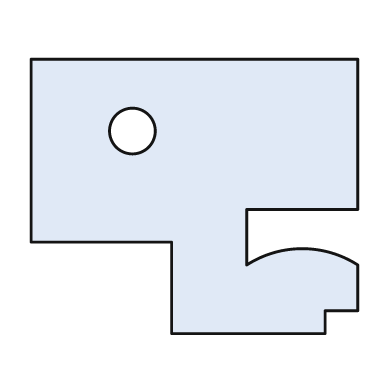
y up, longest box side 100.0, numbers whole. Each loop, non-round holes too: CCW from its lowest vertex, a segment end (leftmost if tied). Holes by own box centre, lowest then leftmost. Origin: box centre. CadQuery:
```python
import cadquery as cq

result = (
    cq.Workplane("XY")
    .moveTo(-7.0, -42.0)
    .lineTo(40.0, -42.0)
    .lineTo(40.0, -35.0)
    .lineTo(50.0, -35.0)
    .lineTo(50.0, -21.0)
    .threePointArc((33.0, -16.0), (16.0, -21.0))
    .lineTo(16.0, -4.0)
    .lineTo(50.0, -4.0)
    .lineTo(50.0, 42.0)
    .lineTo(-50.0, 42.0)
    .lineTo(-50.0, -14.0)
    .lineTo(-7.0, -14.0)
    .close()
    .moveTo(-19.0, 20.0)
    .circle(7.0)
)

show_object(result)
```